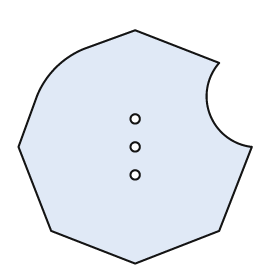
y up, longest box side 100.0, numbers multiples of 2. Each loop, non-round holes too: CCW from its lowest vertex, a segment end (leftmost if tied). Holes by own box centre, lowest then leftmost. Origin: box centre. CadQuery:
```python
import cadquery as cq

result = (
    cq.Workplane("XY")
    .moveTo(0.0, -50.0)
    .lineTo(36.0, -36.0)
    .lineTo(50.0, 0.0)
    .threePointArc((32.0, 14.0), (36.0, 36.0))
    .lineTo(0.0, 50.0)
    .lineTo(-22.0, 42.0)
    .threePointArc((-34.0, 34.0), (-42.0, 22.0))
    .lineTo(-50.0, 0.0)
    .lineTo(-36.0, -36.0)
    .close()
    .moveTo(0.0, -12.0)
    .circle(2.0)
    .moveTo(0.0, 0.0)
    .circle(2.0)
    .moveTo(0.0, 12.0)
    .circle(2.0)
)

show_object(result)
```